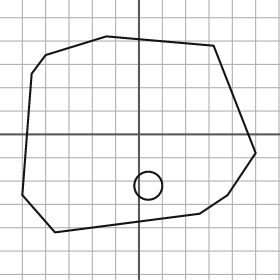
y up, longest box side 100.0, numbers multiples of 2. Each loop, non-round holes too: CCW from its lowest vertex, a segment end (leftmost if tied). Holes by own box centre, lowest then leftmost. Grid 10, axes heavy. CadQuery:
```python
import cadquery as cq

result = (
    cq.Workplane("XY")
    .moveTo(-36.0, -42.0)
    .lineTo(26.0, -34.0)
    .lineTo(38.0, -26.0)
    .lineTo(50.0, -8.0)
    .lineTo(32.0, 38.0)
    .lineTo(-14.0, 42.0)
    .lineTo(-40.0, 34.0)
    .lineTo(-46.0, 26.0)
    .lineTo(-50.0, -26.0)
    .close()
    .moveTo(4.0, -22.0)
    .circle(6.0)
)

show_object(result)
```